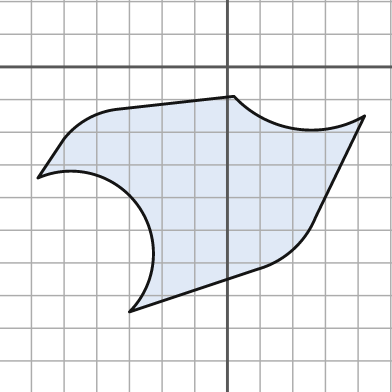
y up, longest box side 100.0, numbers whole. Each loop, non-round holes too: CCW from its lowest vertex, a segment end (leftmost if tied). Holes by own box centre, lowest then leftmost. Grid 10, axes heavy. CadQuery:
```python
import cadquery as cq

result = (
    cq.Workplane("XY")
    .moveTo(-30.0, -75.0)
    .lineTo(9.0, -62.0)
    .threePointArc((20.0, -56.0), (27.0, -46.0))
    .lineTo(42.0, -15.0)
    .threePointArc((21.0, -19.0), (2.0, -9.0))
    .lineTo(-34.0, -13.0)
    .threePointArc((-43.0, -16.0), (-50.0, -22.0))
    .lineTo(-58.0, -34.0)
    .threePointArc((-27.0, -43.0), (-30.0, -75.0))
    .close()
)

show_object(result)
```